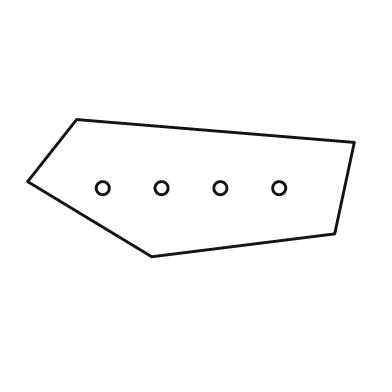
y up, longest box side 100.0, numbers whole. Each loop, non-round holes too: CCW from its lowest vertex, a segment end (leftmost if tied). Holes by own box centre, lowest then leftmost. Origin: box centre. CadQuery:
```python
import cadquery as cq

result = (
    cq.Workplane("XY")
    .moveTo(-12.0, -21.0)
    .lineTo(44.0, -14.0)
    .lineTo(50.0, 14.0)
    .lineTo(-35.0, 21.0)
    .lineTo(-50.0, 2.0)
    .close()
    .moveTo(-27.0, 0.0)
    .circle(2.0)
    .moveTo(-9.0, 0.0)
    .circle(2.0)
    .moveTo(9.0, 0.0)
    .circle(2.0)
    .moveTo(27.0, 0.0)
    .circle(2.0)
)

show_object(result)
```